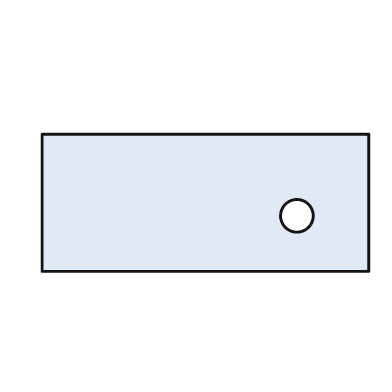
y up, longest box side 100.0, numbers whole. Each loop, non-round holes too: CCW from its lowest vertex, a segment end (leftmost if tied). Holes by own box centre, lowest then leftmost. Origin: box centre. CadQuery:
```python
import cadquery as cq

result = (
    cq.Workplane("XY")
    .moveTo(-50.0, -21.0)
    .lineTo(50.0, -21.0)
    .lineTo(50.0, 21.0)
    .lineTo(-50.0, 21.0)
    .close()
    .moveTo(28.0, -4.0)
    .circle(5.0)
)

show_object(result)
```